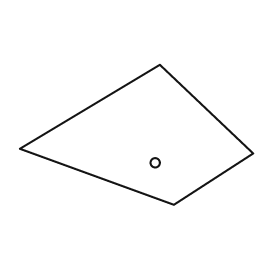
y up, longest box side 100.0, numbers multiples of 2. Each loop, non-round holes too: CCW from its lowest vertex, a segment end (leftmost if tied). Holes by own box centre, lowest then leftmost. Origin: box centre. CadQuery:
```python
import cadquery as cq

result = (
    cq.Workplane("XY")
    .moveTo(16.0, -30.0)
    .lineTo(50.0, -8.0)
    .lineTo(10.0, 30.0)
    .lineTo(-50.0, -6.0)
    .close()
    .moveTo(8.0, -12.0)
    .circle(2.0)
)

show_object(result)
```